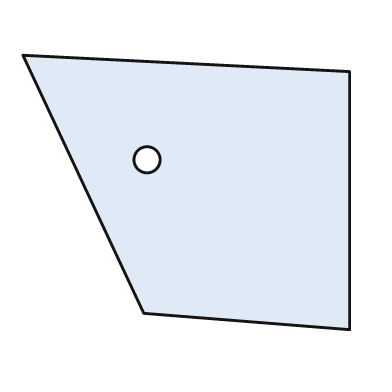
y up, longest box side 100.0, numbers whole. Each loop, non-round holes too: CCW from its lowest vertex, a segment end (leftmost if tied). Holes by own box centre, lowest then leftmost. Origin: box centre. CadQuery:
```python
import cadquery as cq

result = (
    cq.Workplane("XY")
    .moveTo(50.0, -42.0)
    .lineTo(50.0, 37.0)
    .lineTo(-50.0, 42.0)
    .lineTo(-13.0, -37.0)
    .close()
    .moveTo(-12.0, 10.0)
    .circle(4.0)
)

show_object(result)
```